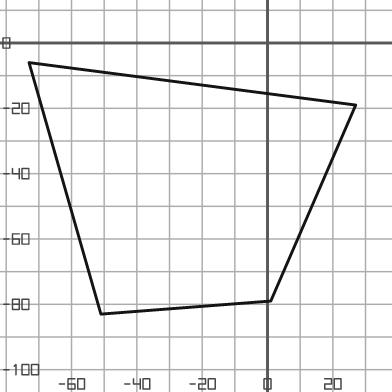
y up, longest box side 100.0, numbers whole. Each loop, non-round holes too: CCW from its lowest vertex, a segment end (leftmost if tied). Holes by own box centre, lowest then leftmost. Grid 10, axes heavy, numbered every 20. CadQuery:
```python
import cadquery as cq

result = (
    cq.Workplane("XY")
    .moveTo(-51.0, -83.0)
    .lineTo(1.0, -79.0)
    .lineTo(27.0, -19.0)
    .lineTo(-73.0, -6.0)
    .close()
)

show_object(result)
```